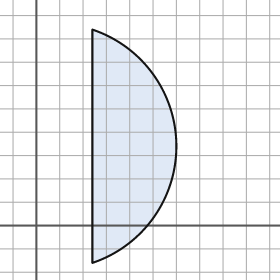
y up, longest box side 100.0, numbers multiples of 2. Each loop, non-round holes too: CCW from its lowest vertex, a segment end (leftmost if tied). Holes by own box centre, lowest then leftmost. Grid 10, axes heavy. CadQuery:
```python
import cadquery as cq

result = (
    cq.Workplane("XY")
    .moveTo(24.0, -16.0)
    .threePointArc((60.0, 34.0), (24.0, 84.0))
    .close()
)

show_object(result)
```